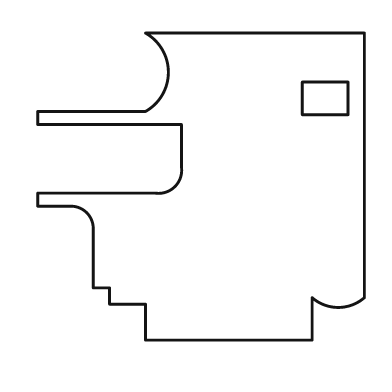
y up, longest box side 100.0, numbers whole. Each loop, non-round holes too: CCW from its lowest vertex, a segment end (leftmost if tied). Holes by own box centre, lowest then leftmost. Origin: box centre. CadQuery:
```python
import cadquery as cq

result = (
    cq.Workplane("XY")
    .moveTo(-17.0, -47.0)
    .lineTo(34.0, -47.0)
    .lineTo(34.0, -34.0)
    .threePointArc((42.0, -37.0), (50.0, -34.0))
    .lineTo(50.0, 47.0)
    .lineTo(-17.0, 47.0)
    .threePointArc((-10.0, 35.0), (-17.0, 23.0))
    .lineTo(-50.0, 23.0)
    .lineTo(-50.0, 19.0)
    .lineTo(-6.0, 19.0)
    .lineTo(-6.0, 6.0)
    .threePointArc((-8.0, 0.0), (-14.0, -2.0))
    .lineTo(-50.0, -2.0)
    .lineTo(-50.0, -6.0)
    .lineTo(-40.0, -6.0)
    .threePointArc((-35.0, -8.0), (-33.0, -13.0))
    .lineTo(-33.0, -31.0)
    .lineTo(-28.0, -31.0)
    .lineTo(-28.0, -36.0)
    .lineTo(-17.0, -36.0)
    .close()
    .moveTo(31.0, 22.0)
    .lineTo(45.0, 22.0)
    .lineTo(45.0, 32.0)
    .lineTo(31.0, 32.0)
    .close()
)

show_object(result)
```